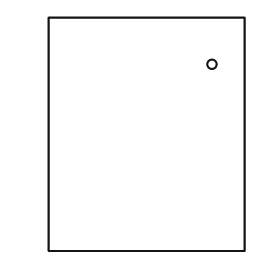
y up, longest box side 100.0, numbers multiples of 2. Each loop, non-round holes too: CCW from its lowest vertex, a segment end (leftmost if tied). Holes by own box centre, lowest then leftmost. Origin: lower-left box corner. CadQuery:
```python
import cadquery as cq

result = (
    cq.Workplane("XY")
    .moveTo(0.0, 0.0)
    .lineTo(84.0, 0.0)
    .lineTo(84.0, 100.0)
    .lineTo(0.0, 100.0)
    .close()
    .moveTo(70.0, 80.0)
    .circle(2.0)
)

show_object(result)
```